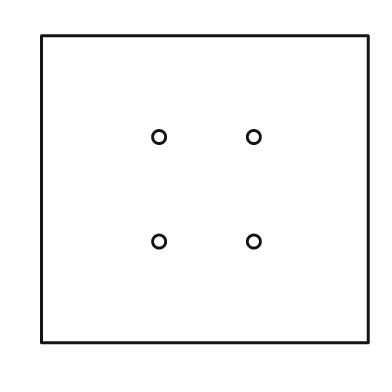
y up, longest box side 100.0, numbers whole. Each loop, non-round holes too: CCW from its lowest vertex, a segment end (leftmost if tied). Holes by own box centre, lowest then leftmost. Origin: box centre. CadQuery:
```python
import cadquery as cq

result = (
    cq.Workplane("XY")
    .moveTo(-50.0, -47.0)
    .lineTo(50.0, -47.0)
    .lineTo(50.0, 47.0)
    .lineTo(-50.0, 47.0)
    .close()
    .moveTo(-14.0, -16.0)
    .circle(2.0)
    .moveTo(15.0, -16.0)
    .circle(2.0)
    .moveTo(-14.0, 16.0)
    .circle(2.0)
    .moveTo(15.0, 16.0)
    .circle(2.0)
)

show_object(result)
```